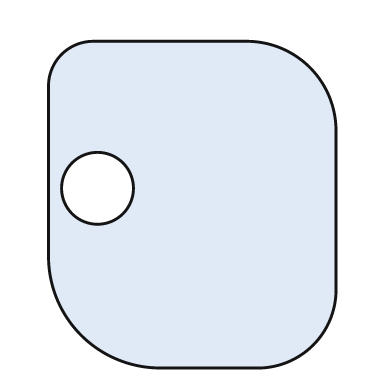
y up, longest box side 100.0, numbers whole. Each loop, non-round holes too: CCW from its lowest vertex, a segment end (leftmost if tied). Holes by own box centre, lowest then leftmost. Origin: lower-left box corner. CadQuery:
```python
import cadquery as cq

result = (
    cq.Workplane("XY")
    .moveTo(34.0, 0.0)
    .lineTo(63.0, 0.0)
    .threePointArc((81.0, 7.0), (88.0, 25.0))
    .lineTo(88.0, 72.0)
    .threePointArc((80.0, 92.0), (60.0, 100.0))
    .lineTo(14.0, 100.0)
    .threePointArc((4.0, 96.0), (0.0, 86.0))
    .lineTo(0.0, 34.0)
    .threePointArc((10.0, 10.0), (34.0, 0.0))
    .close()
    .moveTo(15.0, 55.0)
    .circle(11.0)
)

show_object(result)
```